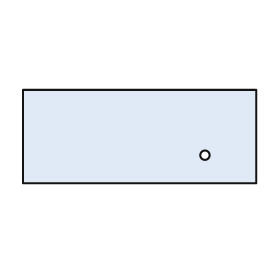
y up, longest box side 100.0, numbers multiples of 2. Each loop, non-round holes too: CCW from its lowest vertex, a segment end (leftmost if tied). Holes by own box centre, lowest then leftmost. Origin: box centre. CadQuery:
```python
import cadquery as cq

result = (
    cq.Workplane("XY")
    .moveTo(-50.0, -20.0)
    .lineTo(50.0, -20.0)
    .lineTo(50.0, 20.0)
    .lineTo(-50.0, 20.0)
    .close()
    .moveTo(28.0, -8.0)
    .circle(2.0)
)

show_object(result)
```